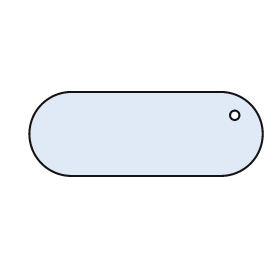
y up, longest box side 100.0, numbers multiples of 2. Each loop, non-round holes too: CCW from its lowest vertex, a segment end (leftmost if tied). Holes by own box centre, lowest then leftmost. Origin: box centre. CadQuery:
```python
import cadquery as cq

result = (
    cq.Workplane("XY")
    .moveTo(-32.0, -18.0)
    .lineTo(32.0, -18.0)
    .threePointArc((50.0, 0.0), (32.0, 18.0))
    .lineTo(-32.0, 18.0)
    .threePointArc((-50.0, 0.0), (-32.0, -18.0))
    .close()
    .moveTo(38.0, 8.0)
    .circle(2.0)
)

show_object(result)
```